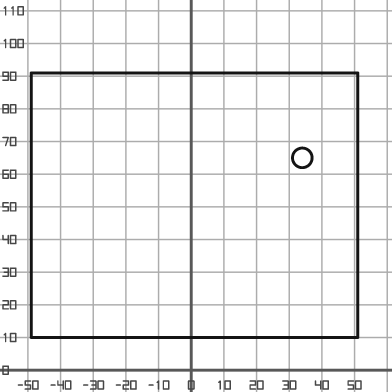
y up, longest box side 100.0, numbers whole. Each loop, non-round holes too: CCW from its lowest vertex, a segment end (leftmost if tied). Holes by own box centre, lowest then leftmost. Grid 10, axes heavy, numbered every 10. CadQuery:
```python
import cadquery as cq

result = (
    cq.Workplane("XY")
    .moveTo(-49.0, 10.0)
    .lineTo(51.0, 10.0)
    .lineTo(51.0, 91.0)
    .lineTo(-49.0, 91.0)
    .close()
    .moveTo(34.0, 65.0)
    .circle(3.0)
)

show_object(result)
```